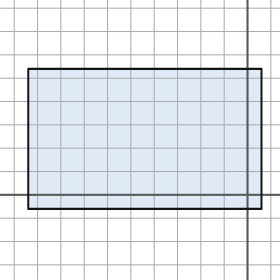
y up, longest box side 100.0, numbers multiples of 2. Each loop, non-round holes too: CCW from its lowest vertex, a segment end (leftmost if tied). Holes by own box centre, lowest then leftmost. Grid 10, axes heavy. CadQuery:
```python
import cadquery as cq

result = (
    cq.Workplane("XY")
    .moveTo(-94.0, -6.0)
    .lineTo(6.0, -6.0)
    .lineTo(6.0, 54.0)
    .lineTo(-94.0, 54.0)
    .close()
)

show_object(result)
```